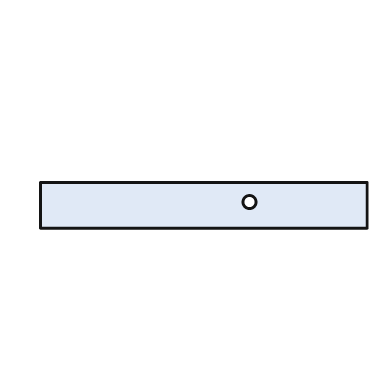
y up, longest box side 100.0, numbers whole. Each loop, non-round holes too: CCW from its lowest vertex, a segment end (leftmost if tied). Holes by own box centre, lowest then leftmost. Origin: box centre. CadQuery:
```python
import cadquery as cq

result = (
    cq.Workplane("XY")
    .moveTo(-50.0, -7.0)
    .lineTo(50.0, -7.0)
    .lineTo(50.0, 7.0)
    .lineTo(-50.0, 7.0)
    .close()
    .moveTo(14.0, 1.0)
    .circle(2.0)
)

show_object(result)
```